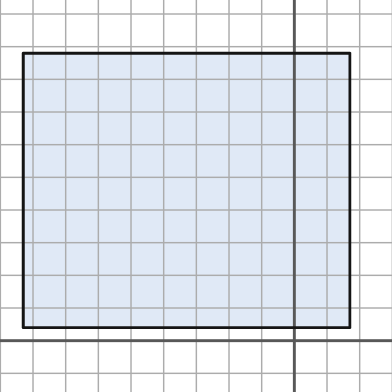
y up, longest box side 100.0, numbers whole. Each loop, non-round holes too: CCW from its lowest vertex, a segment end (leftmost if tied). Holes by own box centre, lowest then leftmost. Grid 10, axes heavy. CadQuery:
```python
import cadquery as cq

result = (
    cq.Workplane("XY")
    .moveTo(-83.0, 4.0)
    .lineTo(17.0, 4.0)
    .lineTo(17.0, 88.0)
    .lineTo(-83.0, 88.0)
    .close()
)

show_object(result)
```